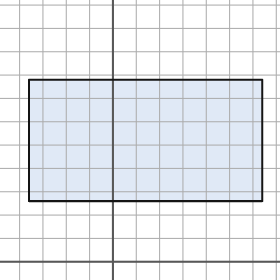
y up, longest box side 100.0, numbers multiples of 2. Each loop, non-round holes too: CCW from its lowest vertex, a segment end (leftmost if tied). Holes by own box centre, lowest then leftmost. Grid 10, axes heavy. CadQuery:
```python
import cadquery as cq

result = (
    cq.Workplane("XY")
    .moveTo(-36.0, 26.0)
    .lineTo(64.0, 26.0)
    .lineTo(64.0, 78.0)
    .lineTo(-36.0, 78.0)
    .close()
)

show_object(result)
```